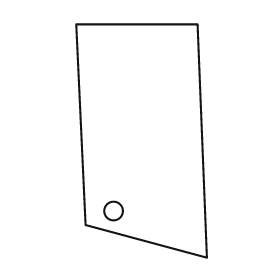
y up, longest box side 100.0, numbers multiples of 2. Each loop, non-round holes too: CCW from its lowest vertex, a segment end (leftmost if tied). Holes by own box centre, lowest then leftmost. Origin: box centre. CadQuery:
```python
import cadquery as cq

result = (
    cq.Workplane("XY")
    .moveTo(28.0, -50.0)
    .lineTo(24.0, 50.0)
    .lineTo(-28.0, 50.0)
    .lineTo(-24.0, -36.0)
    .close()
    .moveTo(-12.0, -30.0)
    .circle(4.0)
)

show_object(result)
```